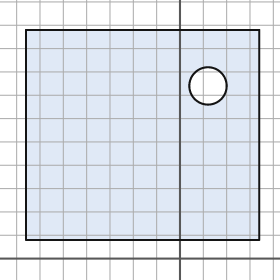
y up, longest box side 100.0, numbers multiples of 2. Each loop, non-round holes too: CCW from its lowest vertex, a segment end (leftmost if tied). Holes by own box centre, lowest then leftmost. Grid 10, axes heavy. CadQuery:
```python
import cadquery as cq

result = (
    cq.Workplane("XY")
    .moveTo(-66.0, 8.0)
    .lineTo(34.0, 8.0)
    .lineTo(34.0, 98.0)
    .lineTo(-66.0, 98.0)
    .close()
    .moveTo(12.0, 74.0)
    .circle(8.0)
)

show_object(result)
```